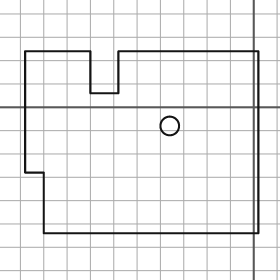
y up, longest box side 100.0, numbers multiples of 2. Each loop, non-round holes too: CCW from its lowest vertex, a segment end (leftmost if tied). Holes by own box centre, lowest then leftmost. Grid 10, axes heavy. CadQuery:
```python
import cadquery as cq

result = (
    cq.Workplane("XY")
    .moveTo(-90.0, -54.0)
    .lineTo(2.0, -54.0)
    .lineTo(2.0, 24.0)
    .lineTo(-58.0, 24.0)
    .lineTo(-58.0, 6.0)
    .lineTo(-70.0, 6.0)
    .lineTo(-70.0, 24.0)
    .lineTo(-98.0, 24.0)
    .lineTo(-98.0, -28.0)
    .lineTo(-90.0, -28.0)
    .close()
    .moveTo(-36.0, -8.0)
    .circle(4.0)
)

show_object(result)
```